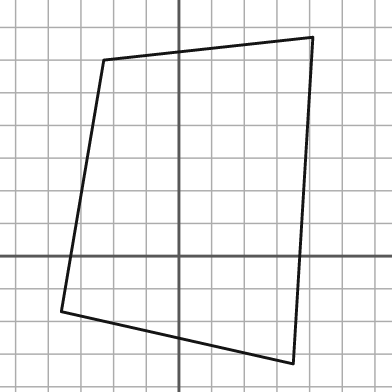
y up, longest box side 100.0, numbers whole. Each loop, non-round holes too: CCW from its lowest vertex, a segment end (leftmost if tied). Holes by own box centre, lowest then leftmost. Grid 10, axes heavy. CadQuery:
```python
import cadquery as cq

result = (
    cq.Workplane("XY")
    .moveTo(35.0, -33.0)
    .lineTo(41.0, 67.0)
    .lineTo(-23.0, 60.0)
    .lineTo(-36.0, -17.0)
    .close()
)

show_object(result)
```